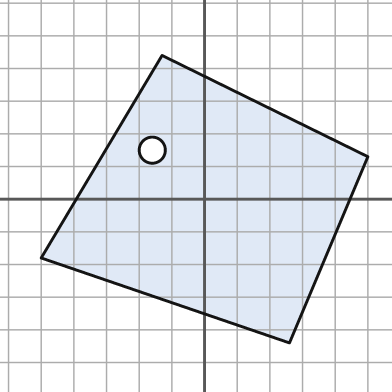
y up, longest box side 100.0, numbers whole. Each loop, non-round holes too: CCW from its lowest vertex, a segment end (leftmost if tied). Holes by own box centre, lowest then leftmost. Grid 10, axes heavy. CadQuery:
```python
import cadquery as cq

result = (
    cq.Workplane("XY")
    .moveTo(26.0, -44.0)
    .lineTo(50.0, 13.0)
    .lineTo(-13.0, 44.0)
    .lineTo(-50.0, -18.0)
    .close()
    .moveTo(-16.0, 15.0)
    .circle(4.0)
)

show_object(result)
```